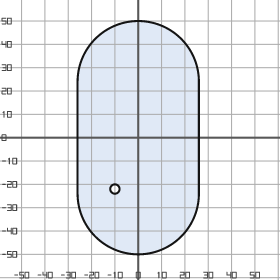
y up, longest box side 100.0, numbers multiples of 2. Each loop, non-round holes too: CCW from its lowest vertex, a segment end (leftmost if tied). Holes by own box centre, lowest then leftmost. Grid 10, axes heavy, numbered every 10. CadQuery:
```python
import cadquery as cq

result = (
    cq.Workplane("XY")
    .moveTo(-26.0, -24.0)
    .threePointArc((0.0, -50.0), (26.0, -24.0))
    .lineTo(26.0, 24.0)
    .threePointArc((0.0, 50.0), (-26.0, 24.0))
    .close()
    .moveTo(-10.0, -22.0)
    .circle(2.0)
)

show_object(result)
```